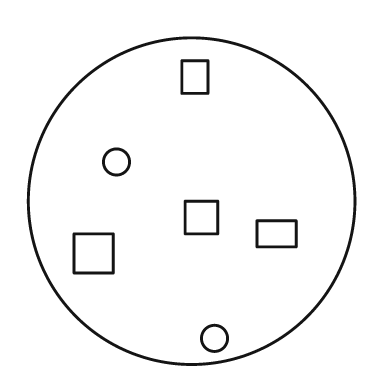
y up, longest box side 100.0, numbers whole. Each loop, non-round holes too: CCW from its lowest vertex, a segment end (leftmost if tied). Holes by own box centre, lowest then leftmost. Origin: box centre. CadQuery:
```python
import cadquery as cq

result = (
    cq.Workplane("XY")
    .moveTo(0.0, 0.0)
    .circle(50.0)
    .moveTo(7.0, -42.0)
    .circle(4.0)
    .moveTo(-36.0, -22.0)
    .lineTo(-24.0, -22.0)
    .lineTo(-24.0, -10.0)
    .lineTo(-36.0, -10.0)
    .close()
    .moveTo(20.0, -14.0)
    .lineTo(32.0, -14.0)
    .lineTo(32.0, -6.0)
    .lineTo(20.0, -6.0)
    .close()
    .moveTo(-2.0, -10.0)
    .lineTo(8.0, -10.0)
    .lineTo(8.0, 0.0)
    .lineTo(-2.0, 0.0)
    .close()
    .moveTo(-23.0, 12.0)
    .circle(4.0)
    .moveTo(-3.0, 33.0)
    .lineTo(5.0, 33.0)
    .lineTo(5.0, 43.0)
    .lineTo(-3.0, 43.0)
    .close()
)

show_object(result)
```